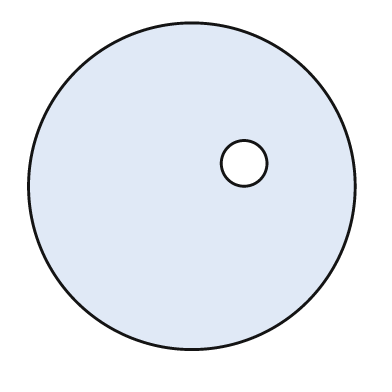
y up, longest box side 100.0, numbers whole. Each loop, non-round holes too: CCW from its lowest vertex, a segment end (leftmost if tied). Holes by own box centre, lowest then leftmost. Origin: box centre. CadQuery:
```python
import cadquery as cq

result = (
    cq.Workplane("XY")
    .moveTo(0.0, 0.0)
    .circle(50.0)
    .moveTo(16.0, 7.0)
    .circle(7.0)
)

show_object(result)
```